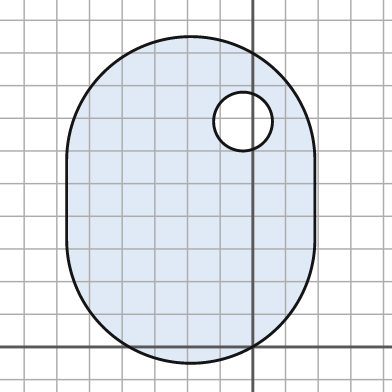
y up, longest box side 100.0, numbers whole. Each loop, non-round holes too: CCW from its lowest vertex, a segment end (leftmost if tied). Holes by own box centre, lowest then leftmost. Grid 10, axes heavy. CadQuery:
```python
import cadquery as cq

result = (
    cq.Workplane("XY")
    .moveTo(-57.0, 33.0)
    .threePointArc((-19.0, -5.0), (19.0, 33.0))
    .lineTo(19.0, 57.0)
    .threePointArc((-19.0, 95.0), (-57.0, 57.0))
    .close()
    .moveTo(-3.0, 69.0)
    .circle(9.0)
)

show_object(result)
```